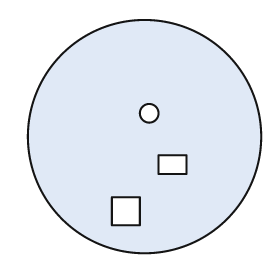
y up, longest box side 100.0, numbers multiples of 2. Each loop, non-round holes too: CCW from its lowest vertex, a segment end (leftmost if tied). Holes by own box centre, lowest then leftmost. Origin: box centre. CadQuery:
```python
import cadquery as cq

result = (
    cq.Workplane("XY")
    .moveTo(0.0, 0.0)
    .circle(50.0)
    .moveTo(-14.0, -38.0)
    .lineTo(-2.0, -38.0)
    .lineTo(-2.0, -26.0)
    .lineTo(-14.0, -26.0)
    .close()
    .moveTo(6.0, -16.0)
    .lineTo(18.0, -16.0)
    .lineTo(18.0, -8.0)
    .lineTo(6.0, -8.0)
    .close()
    .moveTo(2.0, 10.0)
    .circle(4.0)
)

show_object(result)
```